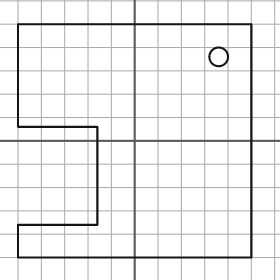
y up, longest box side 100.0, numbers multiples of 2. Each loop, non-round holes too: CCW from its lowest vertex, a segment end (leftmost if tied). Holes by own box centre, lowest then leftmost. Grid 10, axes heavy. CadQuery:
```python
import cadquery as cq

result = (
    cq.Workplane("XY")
    .moveTo(-50.0, -50.0)
    .lineTo(50.0, -50.0)
    .lineTo(50.0, 50.0)
    .lineTo(-50.0, 50.0)
    .lineTo(-50.0, 6.0)
    .lineTo(-16.0, 6.0)
    .lineTo(-16.0, -36.0)
    .lineTo(-50.0, -36.0)
    .close()
    .moveTo(36.0, 36.0)
    .circle(4.0)
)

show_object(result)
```